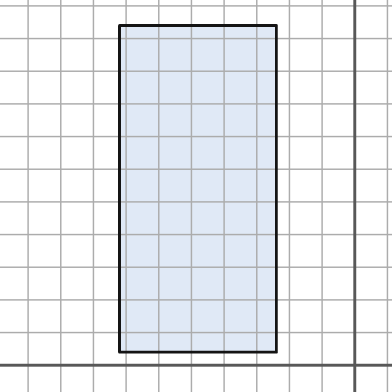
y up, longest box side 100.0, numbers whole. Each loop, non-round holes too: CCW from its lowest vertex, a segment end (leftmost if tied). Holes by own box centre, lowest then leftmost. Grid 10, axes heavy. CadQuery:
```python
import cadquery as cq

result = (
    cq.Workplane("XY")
    .moveTo(-72.0, 4.0)
    .lineTo(-24.0, 4.0)
    .lineTo(-24.0, 104.0)
    .lineTo(-72.0, 104.0)
    .close()
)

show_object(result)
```